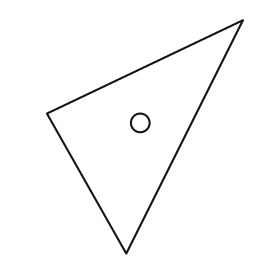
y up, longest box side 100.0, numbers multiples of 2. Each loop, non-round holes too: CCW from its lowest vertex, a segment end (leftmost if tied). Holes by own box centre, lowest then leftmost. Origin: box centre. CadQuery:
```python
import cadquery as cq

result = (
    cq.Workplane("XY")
    .moveTo(-8.0, -50.0)
    .lineTo(42.0, 50.0)
    .lineTo(-42.0, 10.0)
    .close()
    .moveTo(-2.0, 6.0)
    .circle(4.0)
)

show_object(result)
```